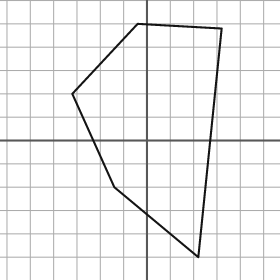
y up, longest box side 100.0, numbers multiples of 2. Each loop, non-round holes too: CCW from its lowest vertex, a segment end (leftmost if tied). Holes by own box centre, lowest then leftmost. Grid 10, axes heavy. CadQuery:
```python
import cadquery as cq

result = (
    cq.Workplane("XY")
    .moveTo(22.0, -50.0)
    .lineTo(32.0, 48.0)
    .lineTo(-4.0, 50.0)
    .lineTo(-32.0, 20.0)
    .lineTo(-14.0, -20.0)
    .close()
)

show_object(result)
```